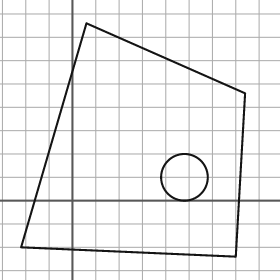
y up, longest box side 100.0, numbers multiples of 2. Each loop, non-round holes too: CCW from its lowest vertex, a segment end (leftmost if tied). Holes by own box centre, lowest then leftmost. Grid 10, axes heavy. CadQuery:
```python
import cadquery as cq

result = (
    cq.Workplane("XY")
    .moveTo(70.0, -24.0)
    .lineTo(74.0, 46.0)
    .lineTo(6.0, 76.0)
    .lineTo(-22.0, -20.0)
    .close()
    .moveTo(48.0, 10.0)
    .circle(10.0)
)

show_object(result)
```